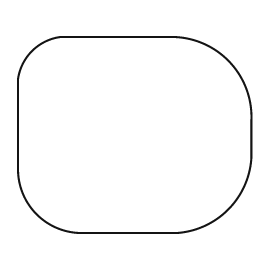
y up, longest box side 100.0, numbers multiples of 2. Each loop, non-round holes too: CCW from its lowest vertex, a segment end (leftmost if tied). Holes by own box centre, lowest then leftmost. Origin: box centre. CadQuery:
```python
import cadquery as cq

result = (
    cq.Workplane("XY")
    .moveTo(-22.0, -42.0)
    .lineTo(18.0, -42.0)
    .threePointArc((40.0, -32.0), (50.0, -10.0))
    .lineTo(50.0, 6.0)
    .threePointArc((40.0, 32.0), (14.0, 42.0))
    .lineTo(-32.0, 42.0)
    .threePointArc((-44.0, 36.0), (-50.0, 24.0))
    .lineTo(-50.0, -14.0)
    .threePointArc((-42.0, -34.0), (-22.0, -42.0))
    .close()
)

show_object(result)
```